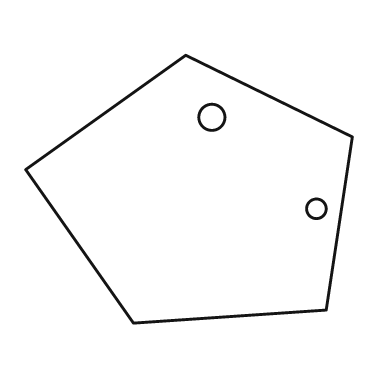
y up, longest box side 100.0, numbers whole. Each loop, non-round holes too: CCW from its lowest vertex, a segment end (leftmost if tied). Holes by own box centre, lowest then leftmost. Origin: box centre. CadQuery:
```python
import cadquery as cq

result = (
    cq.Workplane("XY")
    .moveTo(-17.0, -41.0)
    .lineTo(42.0, -37.0)
    .lineTo(50.0, 16.0)
    .lineTo(-1.0, 41.0)
    .lineTo(-50.0, 6.0)
    .close()
    .moveTo(39.0, -6.0)
    .circle(3.0)
    .moveTo(7.0, 22.0)
    .circle(4.0)
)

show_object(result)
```